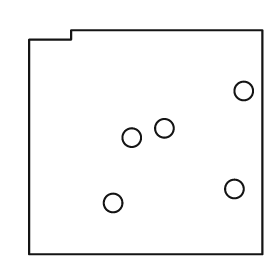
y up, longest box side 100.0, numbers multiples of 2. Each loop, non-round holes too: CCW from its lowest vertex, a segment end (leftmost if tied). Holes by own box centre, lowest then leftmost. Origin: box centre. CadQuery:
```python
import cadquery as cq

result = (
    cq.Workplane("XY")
    .moveTo(-50.0, -48.0)
    .lineTo(50.0, -48.0)
    .lineTo(50.0, 48.0)
    .lineTo(-32.0, 48.0)
    .lineTo(-32.0, 44.0)
    .lineTo(-50.0, 44.0)
    .close()
    .moveTo(-14.0, -26.0)
    .circle(4.0)
    .moveTo(38.0, -20.0)
    .circle(4.0)
    .moveTo(-6.0, 2.0)
    .circle(4.0)
    .moveTo(8.0, 6.0)
    .circle(4.0)
    .moveTo(42.0, 22.0)
    .circle(4.0)
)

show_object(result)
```